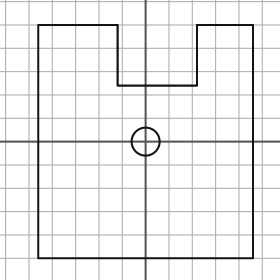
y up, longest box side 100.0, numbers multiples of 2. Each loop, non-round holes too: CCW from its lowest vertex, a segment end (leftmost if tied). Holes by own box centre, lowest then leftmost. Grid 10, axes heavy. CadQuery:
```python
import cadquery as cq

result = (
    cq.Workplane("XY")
    .moveTo(-46.0, -50.0)
    .lineTo(46.0, -50.0)
    .lineTo(46.0, 50.0)
    .lineTo(22.0, 50.0)
    .lineTo(22.0, 24.0)
    .lineTo(-12.0, 24.0)
    .lineTo(-12.0, 50.0)
    .lineTo(-46.0, 50.0)
    .close()
    .moveTo(0.0, 0.0)
    .circle(6.0)
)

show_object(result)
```